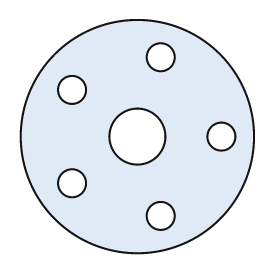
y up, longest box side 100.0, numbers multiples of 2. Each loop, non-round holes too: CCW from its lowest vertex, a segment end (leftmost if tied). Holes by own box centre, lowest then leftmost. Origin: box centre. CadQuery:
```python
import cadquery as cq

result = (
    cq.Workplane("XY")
    .moveTo(0.0, 0.0)
    .circle(50.0)
    .moveTo(10.0, -34.0)
    .circle(6.0)
    .moveTo(-28.0, -20.0)
    .circle(6.0)
    .moveTo(0.0, 0.0)
    .circle(12.0)
    .moveTo(36.0, 0.0)
    .circle(6.0)
    .moveTo(-28.0, 20.0)
    .circle(6.0)
    .moveTo(10.0, 34.0)
    .circle(6.0)
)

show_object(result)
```